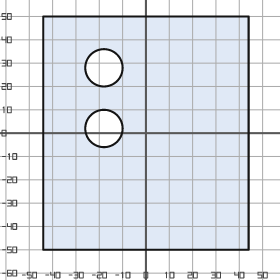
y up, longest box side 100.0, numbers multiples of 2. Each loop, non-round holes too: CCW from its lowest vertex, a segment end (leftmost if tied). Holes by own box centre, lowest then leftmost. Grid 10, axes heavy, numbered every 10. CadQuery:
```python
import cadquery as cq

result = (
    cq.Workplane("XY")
    .moveTo(-44.0, -50.0)
    .lineTo(44.0, -50.0)
    .lineTo(44.0, 50.0)
    .lineTo(-44.0, 50.0)
    .close()
    .moveTo(-18.0, 2.0)
    .circle(8.0)
    .moveTo(-18.0, 28.0)
    .circle(8.0)
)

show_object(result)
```